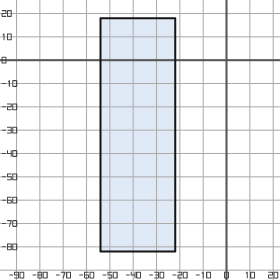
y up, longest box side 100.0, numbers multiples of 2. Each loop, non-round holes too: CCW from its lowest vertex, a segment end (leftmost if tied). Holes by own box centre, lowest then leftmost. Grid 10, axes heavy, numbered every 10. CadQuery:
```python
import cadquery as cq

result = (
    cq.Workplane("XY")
    .moveTo(-54.0, -82.0)
    .lineTo(-22.0, -82.0)
    .lineTo(-22.0, 18.0)
    .lineTo(-54.0, 18.0)
    .close()
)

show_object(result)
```